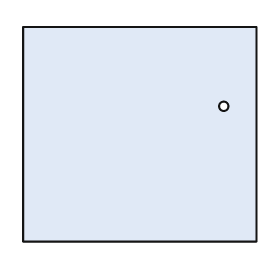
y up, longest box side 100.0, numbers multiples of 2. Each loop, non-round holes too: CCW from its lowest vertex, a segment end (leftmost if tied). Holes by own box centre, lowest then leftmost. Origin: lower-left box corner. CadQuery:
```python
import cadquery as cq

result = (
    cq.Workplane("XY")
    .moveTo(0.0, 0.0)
    .lineTo(100.0, 0.0)
    .lineTo(100.0, 92.0)
    .lineTo(0.0, 92.0)
    .close()
    .moveTo(86.0, 58.0)
    .circle(2.0)
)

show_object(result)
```